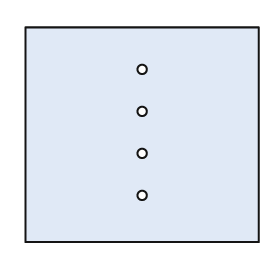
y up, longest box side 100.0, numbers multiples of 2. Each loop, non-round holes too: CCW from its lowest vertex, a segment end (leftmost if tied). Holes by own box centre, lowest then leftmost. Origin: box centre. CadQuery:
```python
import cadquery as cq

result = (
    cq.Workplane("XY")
    .moveTo(-50.0, -46.0)
    .lineTo(50.0, -46.0)
    .lineTo(50.0, 46.0)
    .lineTo(-50.0, 46.0)
    .close()
    .moveTo(0.0, -26.0)
    .circle(2.0)
    .moveTo(0.0, -8.0)
    .circle(2.0)
    .moveTo(0.0, 10.0)
    .circle(2.0)
    .moveTo(0.0, 28.0)
    .circle(2.0)
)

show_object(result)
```